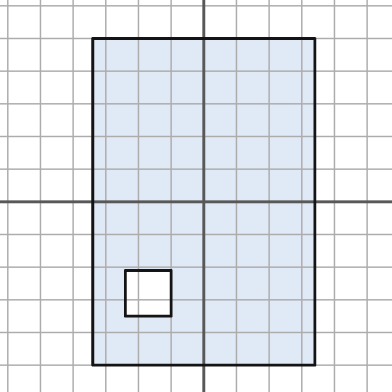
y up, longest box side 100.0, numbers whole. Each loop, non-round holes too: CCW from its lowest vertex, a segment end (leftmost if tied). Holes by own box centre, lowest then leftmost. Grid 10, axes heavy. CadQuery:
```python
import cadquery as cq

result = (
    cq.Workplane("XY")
    .moveTo(-34.0, -50.0)
    .lineTo(34.0, -50.0)
    .lineTo(34.0, 50.0)
    .lineTo(-34.0, 50.0)
    .close()
    .moveTo(-24.0, -35.0)
    .lineTo(-10.0, -35.0)
    .lineTo(-10.0, -21.0)
    .lineTo(-24.0, -21.0)
    .close()
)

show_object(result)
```